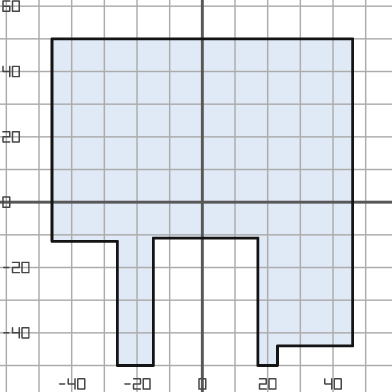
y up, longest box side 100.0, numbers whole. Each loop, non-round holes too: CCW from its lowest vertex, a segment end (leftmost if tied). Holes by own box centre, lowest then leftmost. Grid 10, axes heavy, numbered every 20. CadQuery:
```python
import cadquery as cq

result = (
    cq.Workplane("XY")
    .moveTo(-26.0, -50.0)
    .lineTo(-15.0, -50.0)
    .lineTo(-15.0, -11.0)
    .lineTo(17.0, -11.0)
    .lineTo(17.0, -50.0)
    .lineTo(23.0, -50.0)
    .lineTo(23.0, -44.0)
    .lineTo(46.0, -44.0)
    .lineTo(46.0, 50.0)
    .lineTo(-46.0, 50.0)
    .lineTo(-46.0, -12.0)
    .lineTo(-26.0, -12.0)
    .close()
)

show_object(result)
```